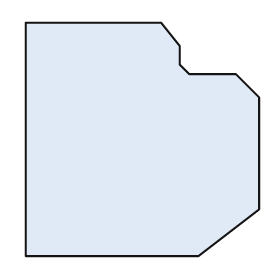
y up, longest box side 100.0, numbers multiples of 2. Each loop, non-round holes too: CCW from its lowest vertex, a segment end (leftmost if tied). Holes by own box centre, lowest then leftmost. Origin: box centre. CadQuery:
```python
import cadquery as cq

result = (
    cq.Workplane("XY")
    .moveTo(-50.0, -50.0)
    .lineTo(24.0, -50.0)
    .lineTo(50.0, -30.0)
    .lineTo(50.0, 18.0)
    .lineTo(40.0, 28.0)
    .lineTo(20.0, 28.0)
    .lineTo(16.0, 32.0)
    .lineTo(16.0, 40.0)
    .lineTo(8.0, 50.0)
    .lineTo(-50.0, 50.0)
    .close()
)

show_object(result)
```